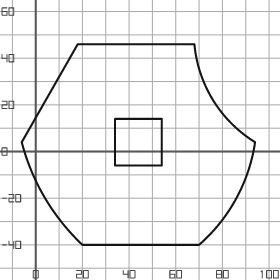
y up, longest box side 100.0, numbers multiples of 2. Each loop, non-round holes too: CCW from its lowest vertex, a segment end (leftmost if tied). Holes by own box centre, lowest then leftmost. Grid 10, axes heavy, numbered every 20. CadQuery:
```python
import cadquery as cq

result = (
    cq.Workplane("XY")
    .moveTo(20.0, -40.0)
    .lineTo(70.0, -40.0)
    .threePointArc((86.0, -20.0), (94.0, 4.0))
    .threePointArc((76.0, 22.0), (68.0, 46.0))
    .lineTo(18.0, 46.0)
    .lineTo(-6.0, 4.0)
    .threePointArc((4.0, -20.0), (20.0, -40.0))
    .close()
    .moveTo(34.0, -6.0)
    .lineTo(54.0, -6.0)
    .lineTo(54.0, 14.0)
    .lineTo(34.0, 14.0)
    .close()
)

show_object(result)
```